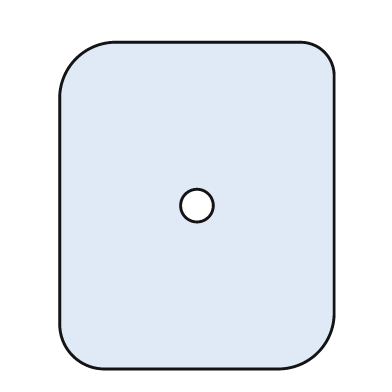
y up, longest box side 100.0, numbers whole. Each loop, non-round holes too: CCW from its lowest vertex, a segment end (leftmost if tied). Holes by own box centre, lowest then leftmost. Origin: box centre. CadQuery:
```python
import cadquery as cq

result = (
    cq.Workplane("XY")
    .moveTo(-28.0, -50.0)
    .lineTo(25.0, -50.0)
    .threePointArc((37.0, -45.0), (42.0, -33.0))
    .lineTo(42.0, 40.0)
    .threePointArc((39.0, 47.0), (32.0, 50.0))
    .lineTo(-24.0, 50.0)
    .threePointArc((-37.0, 45.0), (-42.0, 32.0))
    .lineTo(-42.0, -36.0)
    .threePointArc((-38.0, -46.0), (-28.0, -50.0))
    .close()
    .moveTo(0.0, 0.0)
    .circle(5.0)
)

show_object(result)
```